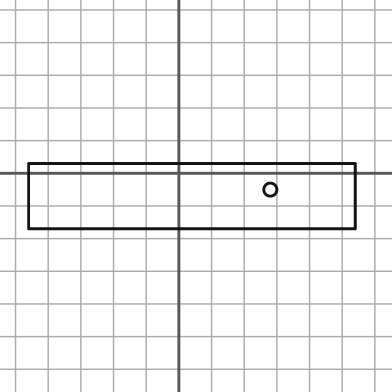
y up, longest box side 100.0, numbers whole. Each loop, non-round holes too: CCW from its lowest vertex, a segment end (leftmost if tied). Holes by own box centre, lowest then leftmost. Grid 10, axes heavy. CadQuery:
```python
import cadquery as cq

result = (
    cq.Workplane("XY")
    .moveTo(-46.0, -17.0)
    .lineTo(54.0, -17.0)
    .lineTo(54.0, 3.0)
    .lineTo(-46.0, 3.0)
    .close()
    .moveTo(28.0, -5.0)
    .circle(2.0)
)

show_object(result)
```